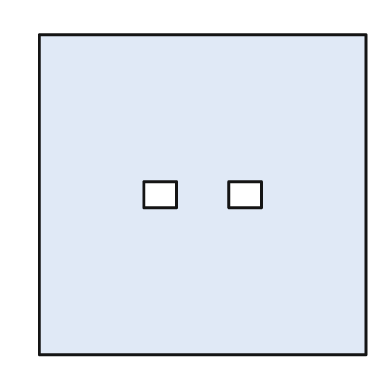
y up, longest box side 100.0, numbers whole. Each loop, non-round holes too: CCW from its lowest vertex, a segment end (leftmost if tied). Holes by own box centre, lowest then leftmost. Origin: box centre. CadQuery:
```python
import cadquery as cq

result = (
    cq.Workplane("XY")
    .moveTo(-50.0, -49.0)
    .lineTo(50.0, -49.0)
    .lineTo(50.0, 49.0)
    .lineTo(-50.0, 49.0)
    .close()
    .moveTo(-18.0, -4.0)
    .lineTo(-8.0, -4.0)
    .lineTo(-8.0, 4.0)
    .lineTo(-18.0, 4.0)
    .close()
    .moveTo(8.0, -4.0)
    .lineTo(18.0, -4.0)
    .lineTo(18.0, 4.0)
    .lineTo(8.0, 4.0)
    .close()
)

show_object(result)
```